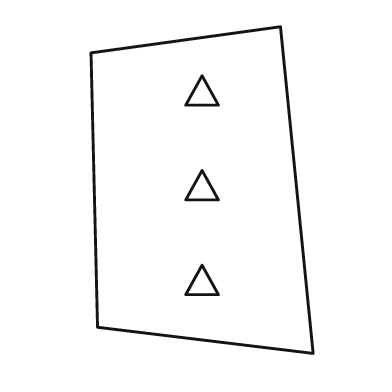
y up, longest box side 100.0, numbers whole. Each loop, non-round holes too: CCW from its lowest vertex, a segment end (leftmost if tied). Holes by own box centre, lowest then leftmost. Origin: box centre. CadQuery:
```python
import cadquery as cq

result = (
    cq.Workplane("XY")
    .moveTo(34.0, -50.0)
    .lineTo(24.0, 50.0)
    .lineTo(-34.0, 42.0)
    .lineTo(-32.0, -42.0)
    .close()
    .moveTo(-5.0, -32.0)
    .lineTo(5.0, -32.0)
    .lineTo(0.0, -23.0)
    .close()
    .moveTo(-5.0, -3.0)
    .lineTo(5.0, -3.0)
    .lineTo(0.0, 6.0)
    .close()
    .moveTo(-5.0, 26.0)
    .lineTo(5.0, 26.0)
    .lineTo(0.0, 35.0)
    .close()
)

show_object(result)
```